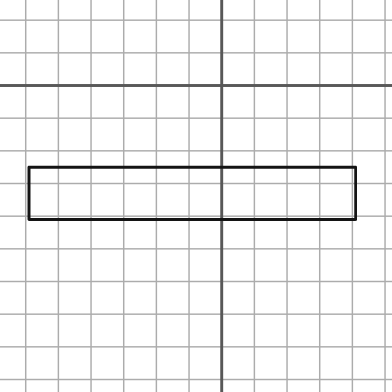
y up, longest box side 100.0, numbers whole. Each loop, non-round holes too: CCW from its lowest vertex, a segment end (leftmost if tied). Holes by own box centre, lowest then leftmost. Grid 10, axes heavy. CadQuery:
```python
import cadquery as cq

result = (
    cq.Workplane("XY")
    .moveTo(-59.0, -41.0)
    .lineTo(41.0, -41.0)
    .lineTo(41.0, -25.0)
    .lineTo(-59.0, -25.0)
    .close()
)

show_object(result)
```